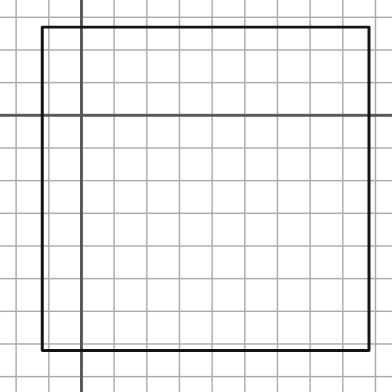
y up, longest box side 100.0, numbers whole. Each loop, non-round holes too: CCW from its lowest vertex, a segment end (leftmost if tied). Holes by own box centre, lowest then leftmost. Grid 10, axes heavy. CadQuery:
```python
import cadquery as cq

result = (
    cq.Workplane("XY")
    .moveTo(-12.0, -72.0)
    .lineTo(88.0, -72.0)
    .lineTo(88.0, 27.0)
    .lineTo(-12.0, 27.0)
    .close()
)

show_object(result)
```